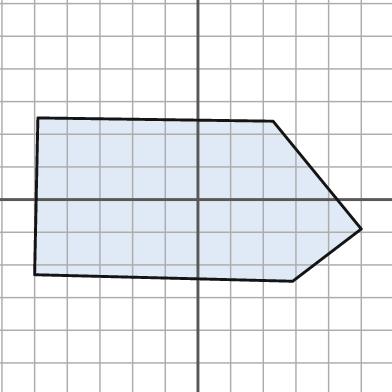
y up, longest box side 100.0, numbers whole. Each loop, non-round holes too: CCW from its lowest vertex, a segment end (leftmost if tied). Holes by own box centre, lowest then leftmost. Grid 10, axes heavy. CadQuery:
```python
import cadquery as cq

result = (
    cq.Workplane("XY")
    .moveTo(29.0, -25.0)
    .lineTo(50.0, -9.0)
    .lineTo(23.0, 24.0)
    .lineTo(-49.0, 25.0)
    .lineTo(-50.0, -23.0)
    .close()
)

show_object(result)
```